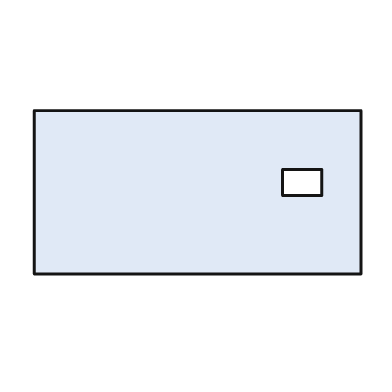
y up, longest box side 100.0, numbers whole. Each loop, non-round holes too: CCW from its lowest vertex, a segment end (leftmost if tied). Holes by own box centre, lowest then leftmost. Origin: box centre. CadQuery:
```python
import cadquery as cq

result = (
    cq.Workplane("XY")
    .moveTo(-50.0, -25.0)
    .lineTo(50.0, -25.0)
    .lineTo(50.0, 25.0)
    .lineTo(-50.0, 25.0)
    .close()
    .moveTo(26.0, -1.0)
    .lineTo(38.0, -1.0)
    .lineTo(38.0, 7.0)
    .lineTo(26.0, 7.0)
    .close()
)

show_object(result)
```